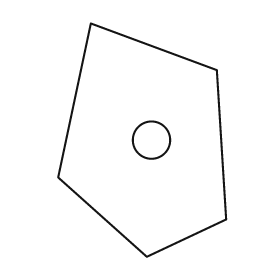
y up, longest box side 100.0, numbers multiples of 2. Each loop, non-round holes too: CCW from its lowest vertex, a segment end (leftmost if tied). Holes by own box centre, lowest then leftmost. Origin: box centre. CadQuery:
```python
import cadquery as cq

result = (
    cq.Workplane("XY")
    .moveTo(2.0, -50.0)
    .lineTo(36.0, -34.0)
    .lineTo(32.0, 30.0)
    .lineTo(-22.0, 50.0)
    .lineTo(-36.0, -16.0)
    .close()
    .moveTo(4.0, 0.0)
    .circle(8.0)
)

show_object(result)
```